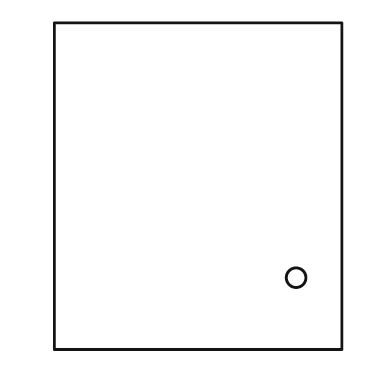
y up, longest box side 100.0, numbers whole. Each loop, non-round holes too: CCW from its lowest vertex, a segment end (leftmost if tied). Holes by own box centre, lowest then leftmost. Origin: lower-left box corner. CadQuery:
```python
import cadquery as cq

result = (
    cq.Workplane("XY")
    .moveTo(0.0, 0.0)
    .lineTo(88.0, 0.0)
    .lineTo(88.0, 100.0)
    .lineTo(0.0, 100.0)
    .close()
    .moveTo(74.0, 22.0)
    .circle(3.0)
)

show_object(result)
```